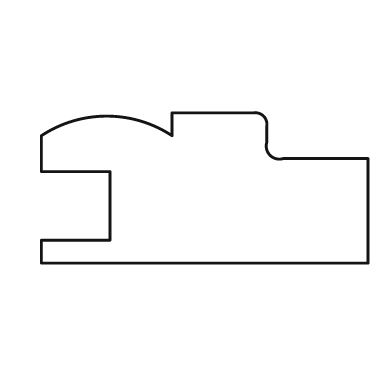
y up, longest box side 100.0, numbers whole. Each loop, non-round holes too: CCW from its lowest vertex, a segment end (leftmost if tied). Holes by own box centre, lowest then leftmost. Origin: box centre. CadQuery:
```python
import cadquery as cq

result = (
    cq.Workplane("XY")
    .moveTo(-50.0, -23.0)
    .lineTo(50.0, -23.0)
    .lineTo(50.0, 9.0)
    .lineTo(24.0, 9.0)
    .threePointArc((20.0, 10.0), (19.0, 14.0))
    .lineTo(19.0, 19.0)
    .threePointArc((18.0, 22.0), (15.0, 23.0))
    .lineTo(-10.0, 23.0)
    .lineTo(-10.0, 16.0)
    .threePointArc((-30.0, 22.0), (-50.0, 16.0))
    .lineTo(-50.0, 5.0)
    .lineTo(-29.0, 5.0)
    .lineTo(-29.0, -16.0)
    .lineTo(-50.0, -16.0)
    .close()
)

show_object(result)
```